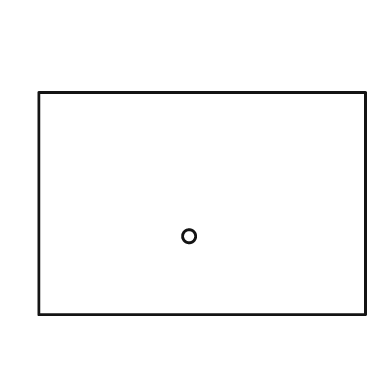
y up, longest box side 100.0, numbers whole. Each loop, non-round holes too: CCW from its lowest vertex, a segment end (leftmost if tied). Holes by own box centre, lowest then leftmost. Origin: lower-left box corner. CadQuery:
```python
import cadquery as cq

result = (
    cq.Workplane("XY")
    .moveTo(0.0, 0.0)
    .lineTo(100.0, 0.0)
    .lineTo(100.0, 68.0)
    .lineTo(0.0, 68.0)
    .close()
    .moveTo(46.0, 24.0)
    .circle(2.0)
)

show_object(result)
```